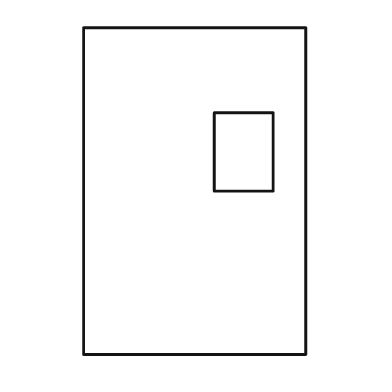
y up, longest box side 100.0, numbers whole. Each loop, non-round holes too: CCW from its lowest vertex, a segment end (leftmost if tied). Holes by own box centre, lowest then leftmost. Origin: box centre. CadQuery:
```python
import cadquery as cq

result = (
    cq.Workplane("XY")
    .moveTo(-34.0, -50.0)
    .lineTo(34.0, -50.0)
    .lineTo(34.0, 50.0)
    .lineTo(-34.0, 50.0)
    .close()
    .moveTo(6.0, 0.0)
    .lineTo(24.0, 0.0)
    .lineTo(24.0, 24.0)
    .lineTo(6.0, 24.0)
    .close()
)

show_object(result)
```